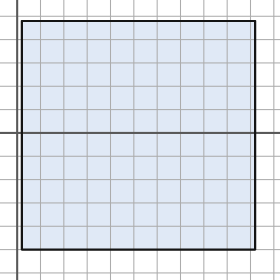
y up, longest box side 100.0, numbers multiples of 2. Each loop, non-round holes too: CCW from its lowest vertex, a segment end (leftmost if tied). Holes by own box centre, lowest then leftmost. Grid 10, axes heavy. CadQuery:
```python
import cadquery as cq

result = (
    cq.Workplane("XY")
    .moveTo(2.0, -50.0)
    .lineTo(102.0, -50.0)
    .lineTo(102.0, 48.0)
    .lineTo(2.0, 48.0)
    .close()
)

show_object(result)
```